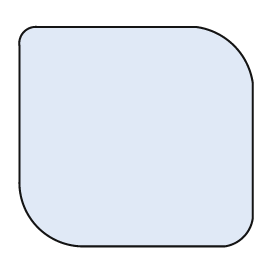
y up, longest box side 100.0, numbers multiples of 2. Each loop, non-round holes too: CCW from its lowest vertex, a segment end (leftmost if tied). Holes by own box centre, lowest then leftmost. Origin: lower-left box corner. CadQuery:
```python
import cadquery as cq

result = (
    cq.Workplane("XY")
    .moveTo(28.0, 0.0)
    .lineTo(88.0, 0.0)
    .threePointArc((96.0, 4.0), (100.0, 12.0))
    .lineTo(100.0, 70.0)
    .threePointArc((92.0, 86.0), (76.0, 94.0))
    .lineTo(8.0, 94.0)
    .threePointArc((2.0, 92.0), (0.0, 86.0))
    .lineTo(0.0, 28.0)
    .threePointArc((8.0, 8.0), (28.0, 0.0))
    .close()
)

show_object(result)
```